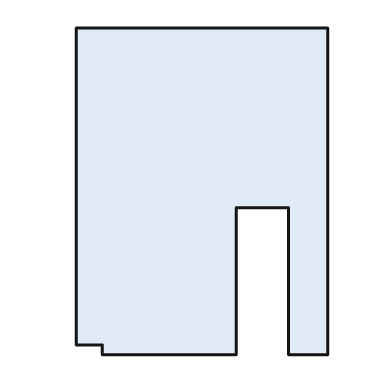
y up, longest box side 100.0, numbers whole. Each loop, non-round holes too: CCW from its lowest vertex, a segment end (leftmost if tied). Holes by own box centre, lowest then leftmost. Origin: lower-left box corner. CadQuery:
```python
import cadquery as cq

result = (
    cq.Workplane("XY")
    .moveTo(8.0, 0.0)
    .lineTo(49.0, 0.0)
    .lineTo(49.0, 45.0)
    .lineTo(65.0, 45.0)
    .lineTo(65.0, 0.0)
    .lineTo(77.0, 0.0)
    .lineTo(77.0, 100.0)
    .lineTo(0.0, 100.0)
    .lineTo(0.0, 3.0)
    .lineTo(8.0, 3.0)
    .close()
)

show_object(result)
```